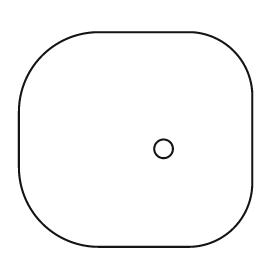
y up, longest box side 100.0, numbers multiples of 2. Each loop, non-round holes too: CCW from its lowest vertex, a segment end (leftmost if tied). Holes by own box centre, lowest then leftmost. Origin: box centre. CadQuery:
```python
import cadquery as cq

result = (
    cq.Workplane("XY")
    .moveTo(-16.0, -46.0)
    .lineTo(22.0, -46.0)
    .threePointArc((42.0, -38.0), (50.0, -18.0))
    .lineTo(50.0, 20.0)
    .threePointArc((42.0, 38.0), (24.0, 46.0))
    .lineTo(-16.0, 46.0)
    .threePointArc((-40.0, 36.0), (-50.0, 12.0))
    .lineTo(-50.0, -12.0)
    .threePointArc((-40.0, -36.0), (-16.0, -46.0))
    .close()
    .moveTo(12.0, -4.0)
    .circle(4.0)
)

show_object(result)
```